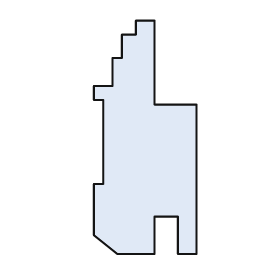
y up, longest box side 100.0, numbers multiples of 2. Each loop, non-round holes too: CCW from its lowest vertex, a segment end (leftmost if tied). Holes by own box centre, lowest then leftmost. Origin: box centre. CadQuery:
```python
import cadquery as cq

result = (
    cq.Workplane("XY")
    .moveTo(-12.0, -50.0)
    .lineTo(4.0, -50.0)
    .lineTo(4.0, -34.0)
    .lineTo(14.0, -34.0)
    .lineTo(14.0, -50.0)
    .lineTo(22.0, -50.0)
    .lineTo(22.0, 14.0)
    .lineTo(4.0, 14.0)
    .lineTo(4.0, 50.0)
    .lineTo(-4.0, 50.0)
    .lineTo(-4.0, 44.0)
    .lineTo(-10.0, 44.0)
    .lineTo(-10.0, 34.0)
    .lineTo(-14.0, 34.0)
    .lineTo(-14.0, 22.0)
    .lineTo(-22.0, 22.0)
    .lineTo(-22.0, 16.0)
    .lineTo(-18.0, 16.0)
    .lineTo(-18.0, -20.0)
    .lineTo(-22.0, -20.0)
    .lineTo(-22.0, -42.0)
    .close()
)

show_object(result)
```